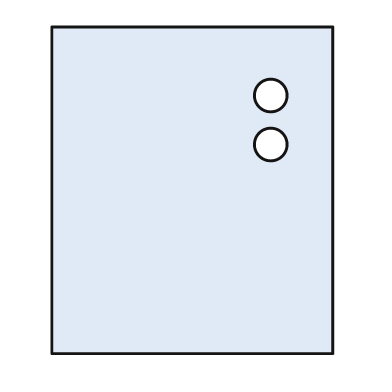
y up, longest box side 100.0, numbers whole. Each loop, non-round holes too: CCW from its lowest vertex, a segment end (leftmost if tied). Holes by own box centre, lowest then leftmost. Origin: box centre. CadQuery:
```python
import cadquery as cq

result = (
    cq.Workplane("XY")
    .moveTo(-43.0, -50.0)
    .lineTo(43.0, -50.0)
    .lineTo(43.0, 50.0)
    .lineTo(-43.0, 50.0)
    .close()
    .moveTo(24.0, 14.0)
    .circle(5.0)
    .moveTo(24.0, 29.0)
    .circle(5.0)
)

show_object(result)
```